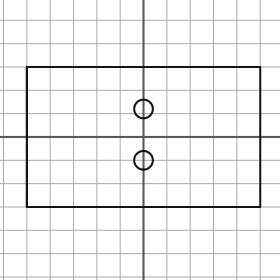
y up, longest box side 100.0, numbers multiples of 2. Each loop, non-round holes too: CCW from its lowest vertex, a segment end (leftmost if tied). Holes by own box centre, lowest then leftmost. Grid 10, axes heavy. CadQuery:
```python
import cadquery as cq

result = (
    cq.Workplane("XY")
    .moveTo(-50.0, -30.0)
    .lineTo(50.0, -30.0)
    .lineTo(50.0, 30.0)
    .lineTo(-50.0, 30.0)
    .close()
    .moveTo(0.0, -10.0)
    .circle(4.0)
    .moveTo(0.0, 12.0)
    .circle(4.0)
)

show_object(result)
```